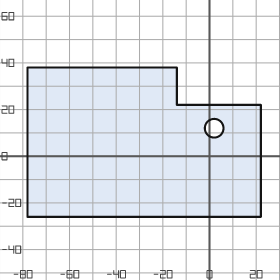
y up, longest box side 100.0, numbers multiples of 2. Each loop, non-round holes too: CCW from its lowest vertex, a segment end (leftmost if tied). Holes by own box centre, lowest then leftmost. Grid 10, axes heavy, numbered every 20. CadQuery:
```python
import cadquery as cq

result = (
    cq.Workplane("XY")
    .moveTo(-78.0, -26.0)
    .lineTo(22.0, -26.0)
    .lineTo(22.0, 22.0)
    .lineTo(-14.0, 22.0)
    .lineTo(-14.0, 38.0)
    .lineTo(-78.0, 38.0)
    .close()
    .moveTo(2.0, 12.0)
    .circle(4.0)
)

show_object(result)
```